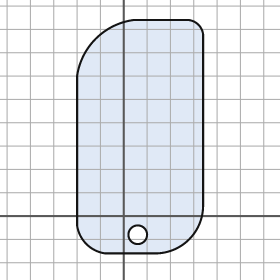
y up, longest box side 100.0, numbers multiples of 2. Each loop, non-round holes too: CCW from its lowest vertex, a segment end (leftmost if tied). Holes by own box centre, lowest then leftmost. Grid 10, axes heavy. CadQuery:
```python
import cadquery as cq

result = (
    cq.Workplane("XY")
    .moveTo(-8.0, -16.0)
    .lineTo(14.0, -16.0)
    .threePointArc((28.0, -10.0), (34.0, 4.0))
    .lineTo(34.0, 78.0)
    .threePointArc((32.0, 82.0), (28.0, 84.0))
    .lineTo(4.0, 84.0)
    .threePointArc((-12.0, 76.0), (-20.0, 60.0))
    .lineTo(-20.0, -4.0)
    .threePointArc((-16.0, -12.0), (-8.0, -16.0))
    .close()
    .moveTo(6.0, -8.0)
    .circle(4.0)
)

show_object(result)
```